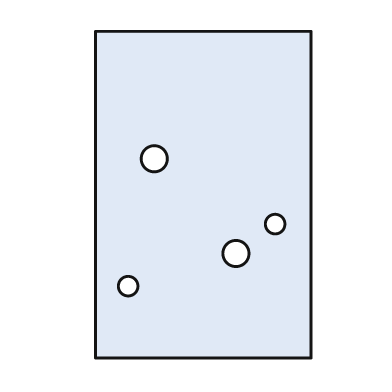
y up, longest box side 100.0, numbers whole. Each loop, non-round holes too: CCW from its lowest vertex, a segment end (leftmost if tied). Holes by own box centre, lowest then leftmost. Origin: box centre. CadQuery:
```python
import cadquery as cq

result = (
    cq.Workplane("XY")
    .moveTo(-33.0, -50.0)
    .lineTo(33.0, -50.0)
    .lineTo(33.0, 50.0)
    .lineTo(-33.0, 50.0)
    .close()
    .moveTo(-23.0, -28.0)
    .circle(3.0)
    .moveTo(10.0, -18.0)
    .circle(4.0)
    .moveTo(22.0, -9.0)
    .circle(3.0)
    .moveTo(-15.0, 11.0)
    .circle(4.0)
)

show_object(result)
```